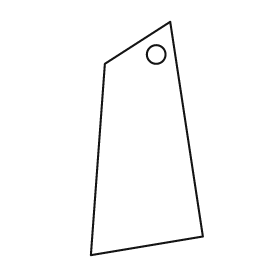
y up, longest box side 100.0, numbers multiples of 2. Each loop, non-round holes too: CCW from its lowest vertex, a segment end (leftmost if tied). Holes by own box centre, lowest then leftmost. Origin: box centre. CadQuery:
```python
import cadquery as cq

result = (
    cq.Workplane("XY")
    .moveTo(-24.0, -50.0)
    .lineTo(24.0, -42.0)
    .lineTo(10.0, 50.0)
    .lineTo(-18.0, 32.0)
    .close()
    .moveTo(4.0, 36.0)
    .circle(4.0)
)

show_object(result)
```